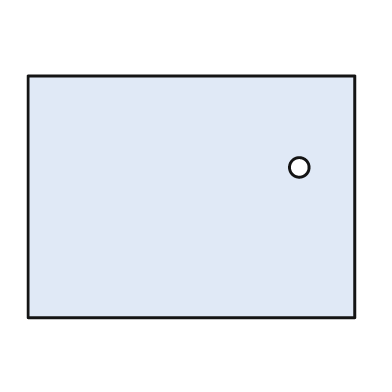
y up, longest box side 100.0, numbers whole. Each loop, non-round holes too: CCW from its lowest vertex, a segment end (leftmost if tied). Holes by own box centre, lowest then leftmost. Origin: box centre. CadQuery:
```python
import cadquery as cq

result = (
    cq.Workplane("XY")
    .moveTo(-50.0, -37.0)
    .lineTo(50.0, -37.0)
    .lineTo(50.0, 37.0)
    .lineTo(-50.0, 37.0)
    .close()
    .moveTo(33.0, 9.0)
    .circle(3.0)
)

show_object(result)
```